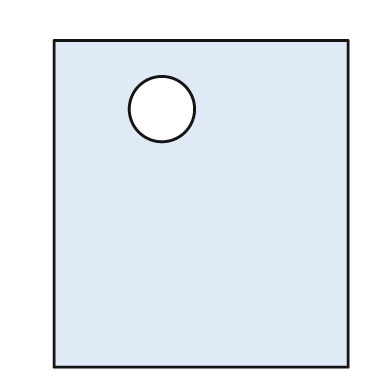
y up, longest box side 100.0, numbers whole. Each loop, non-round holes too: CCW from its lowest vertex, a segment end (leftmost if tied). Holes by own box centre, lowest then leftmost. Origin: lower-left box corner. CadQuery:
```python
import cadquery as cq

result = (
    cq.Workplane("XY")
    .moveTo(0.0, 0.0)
    .lineTo(90.0, 0.0)
    .lineTo(90.0, 100.0)
    .lineTo(0.0, 100.0)
    .close()
    .moveTo(33.0, 79.0)
    .circle(10.0)
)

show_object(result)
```